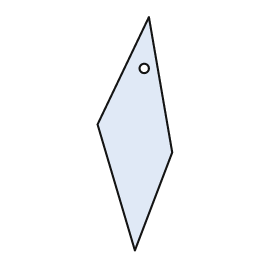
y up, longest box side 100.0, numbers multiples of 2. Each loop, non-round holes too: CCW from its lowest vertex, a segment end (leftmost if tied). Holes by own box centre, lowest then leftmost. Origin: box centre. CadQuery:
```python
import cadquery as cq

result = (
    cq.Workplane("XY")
    .moveTo(0.0, -50.0)
    .lineTo(16.0, -8.0)
    .lineTo(6.0, 50.0)
    .lineTo(-16.0, 4.0)
    .close()
    .moveTo(4.0, 28.0)
    .circle(2.0)
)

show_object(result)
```